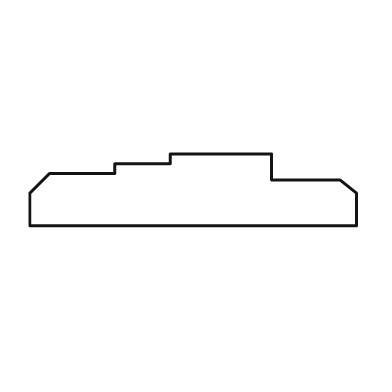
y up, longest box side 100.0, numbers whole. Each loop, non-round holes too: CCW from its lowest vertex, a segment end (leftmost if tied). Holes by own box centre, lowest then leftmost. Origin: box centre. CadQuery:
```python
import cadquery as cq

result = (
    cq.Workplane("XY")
    .moveTo(-50.0, -11.0)
    .lineTo(50.0, -11.0)
    .lineTo(50.0, -1.0)
    .lineTo(45.0, 3.0)
    .lineTo(24.0, 3.0)
    .lineTo(24.0, 11.0)
    .lineTo(-7.0, 11.0)
    .lineTo(-7.0, 8.0)
    .lineTo(-24.0, 8.0)
    .lineTo(-24.0, 5.0)
    .lineTo(-44.0, 5.0)
    .lineTo(-50.0, -1.0)
    .close()
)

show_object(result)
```